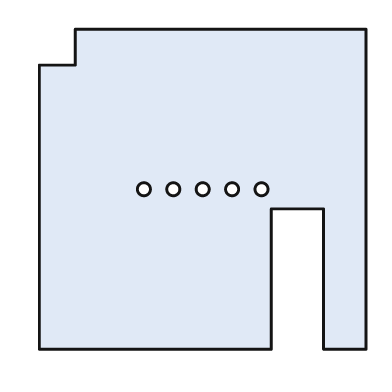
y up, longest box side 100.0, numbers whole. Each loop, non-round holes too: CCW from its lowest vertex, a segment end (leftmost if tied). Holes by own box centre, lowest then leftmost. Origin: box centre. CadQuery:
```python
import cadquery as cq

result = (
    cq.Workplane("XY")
    .moveTo(-50.0, -49.0)
    .lineTo(21.0, -49.0)
    .lineTo(21.0, -6.0)
    .lineTo(37.0, -6.0)
    .lineTo(37.0, -49.0)
    .lineTo(50.0, -49.0)
    .lineTo(50.0, 49.0)
    .lineTo(-39.0, 49.0)
    .lineTo(-39.0, 38.0)
    .lineTo(-50.0, 38.0)
    .close()
    .moveTo(-18.0, 0.0)
    .circle(2.0)
    .moveTo(-9.0, 0.0)
    .circle(2.0)
    .moveTo(0.0, 0.0)
    .circle(2.0)
    .moveTo(9.0, 0.0)
    .circle(2.0)
    .moveTo(18.0, 0.0)
    .circle(2.0)
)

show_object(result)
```